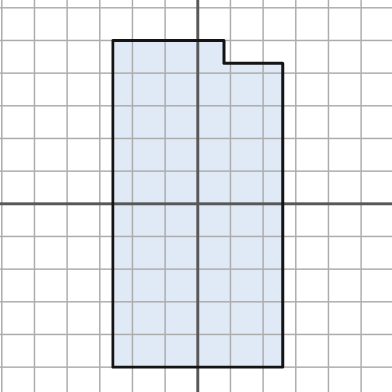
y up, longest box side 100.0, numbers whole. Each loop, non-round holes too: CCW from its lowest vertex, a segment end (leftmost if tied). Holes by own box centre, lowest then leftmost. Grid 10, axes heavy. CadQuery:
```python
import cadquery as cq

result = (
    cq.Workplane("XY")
    .moveTo(-26.0, -50.0)
    .lineTo(26.0, -50.0)
    .lineTo(26.0, 43.0)
    .lineTo(8.0, 43.0)
    .lineTo(8.0, 50.0)
    .lineTo(-26.0, 50.0)
    .close()
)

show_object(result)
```